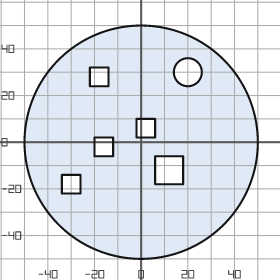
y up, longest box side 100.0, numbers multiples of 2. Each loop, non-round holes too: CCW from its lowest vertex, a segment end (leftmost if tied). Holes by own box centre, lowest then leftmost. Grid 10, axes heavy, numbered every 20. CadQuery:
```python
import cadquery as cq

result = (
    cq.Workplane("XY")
    .moveTo(0.0, 0.0)
    .circle(50.0)
    .moveTo(-34.0, -22.0)
    .lineTo(-26.0, -22.0)
    .lineTo(-26.0, -14.0)
    .lineTo(-34.0, -14.0)
    .close()
    .moveTo(6.0, -18.0)
    .lineTo(18.0, -18.0)
    .lineTo(18.0, -6.0)
    .lineTo(6.0, -6.0)
    .close()
    .moveTo(-20.0, -6.0)
    .lineTo(-12.0, -6.0)
    .lineTo(-12.0, 2.0)
    .lineTo(-20.0, 2.0)
    .close()
    .moveTo(-2.0, 2.0)
    .lineTo(6.0, 2.0)
    .lineTo(6.0, 10.0)
    .lineTo(-2.0, 10.0)
    .close()
    .moveTo(-22.0, 24.0)
    .lineTo(-14.0, 24.0)
    .lineTo(-14.0, 32.0)
    .lineTo(-22.0, 32.0)
    .close()
    .moveTo(20.0, 30.0)
    .circle(6.0)
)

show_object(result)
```